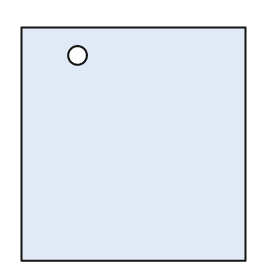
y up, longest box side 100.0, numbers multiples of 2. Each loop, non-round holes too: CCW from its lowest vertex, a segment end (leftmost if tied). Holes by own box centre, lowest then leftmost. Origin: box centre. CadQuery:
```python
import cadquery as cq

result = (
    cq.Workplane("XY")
    .moveTo(-48.0, -50.0)
    .lineTo(48.0, -50.0)
    .lineTo(48.0, 50.0)
    .lineTo(-48.0, 50.0)
    .close()
    .moveTo(-24.0, 38.0)
    .circle(4.0)
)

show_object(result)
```